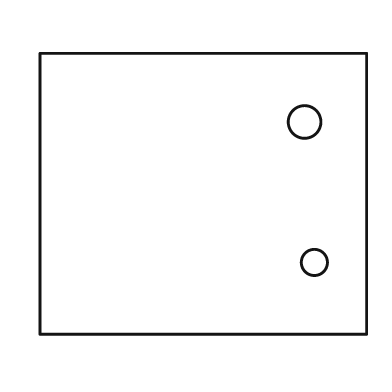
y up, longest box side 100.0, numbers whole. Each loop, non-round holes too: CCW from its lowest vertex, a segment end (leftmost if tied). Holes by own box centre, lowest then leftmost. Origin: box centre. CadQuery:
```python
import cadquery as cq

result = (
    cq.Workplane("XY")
    .moveTo(-50.0, -43.0)
    .lineTo(50.0, -43.0)
    .lineTo(50.0, 43.0)
    .lineTo(-50.0, 43.0)
    .close()
    .moveTo(34.0, -21.0)
    .circle(4.0)
    .moveTo(31.0, 22.0)
    .circle(5.0)
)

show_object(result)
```